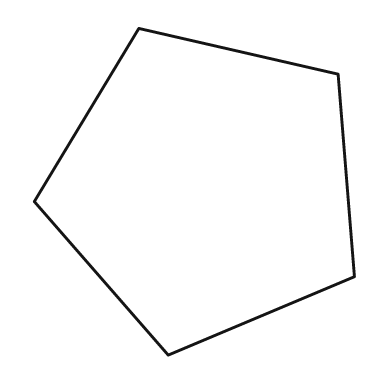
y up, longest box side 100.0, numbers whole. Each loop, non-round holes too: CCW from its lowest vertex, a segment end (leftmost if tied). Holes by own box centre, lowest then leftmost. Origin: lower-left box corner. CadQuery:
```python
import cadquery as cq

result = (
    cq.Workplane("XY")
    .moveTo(41.0, 0.0)
    .lineTo(98.0, 24.0)
    .lineTo(93.0, 86.0)
    .lineTo(32.0, 100.0)
    .lineTo(0.0, 47.0)
    .close()
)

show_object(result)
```